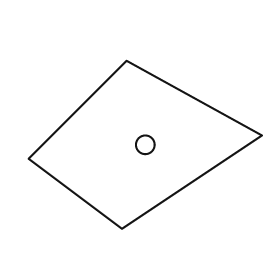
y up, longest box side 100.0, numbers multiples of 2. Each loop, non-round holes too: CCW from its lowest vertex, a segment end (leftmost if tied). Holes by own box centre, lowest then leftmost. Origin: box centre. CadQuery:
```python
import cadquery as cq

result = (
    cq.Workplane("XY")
    .moveTo(-10.0, -36.0)
    .lineTo(50.0, 4.0)
    .lineTo(-8.0, 36.0)
    .lineTo(-50.0, -6.0)
    .close()
    .moveTo(0.0, 0.0)
    .circle(4.0)
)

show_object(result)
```